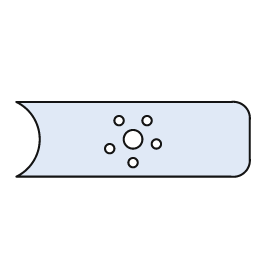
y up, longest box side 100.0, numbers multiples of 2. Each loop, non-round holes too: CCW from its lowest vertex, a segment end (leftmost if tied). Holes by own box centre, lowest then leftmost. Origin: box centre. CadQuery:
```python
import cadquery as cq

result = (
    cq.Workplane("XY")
    .moveTo(-50.0, -16.0)
    .lineTo(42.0, -16.0)
    .threePointArc((48.0, -14.0), (50.0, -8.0))
    .lineTo(50.0, 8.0)
    .threePointArc((48.0, 14.0), (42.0, 16.0))
    .lineTo(-50.0, 16.0)
    .threePointArc((-40.0, 0.0), (-50.0, -16.0))
    .close()
    .moveTo(0.0, -10.0)
    .circle(2.0)
    .moveTo(-10.0, -4.0)
    .circle(2.0)
    .moveTo(10.0, -2.0)
    .circle(2.0)
    .moveTo(0.0, 0.0)
    .circle(4.0)
    .moveTo(-6.0, 8.0)
    .circle(2.0)
    .moveTo(6.0, 8.0)
    .circle(2.0)
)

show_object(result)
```